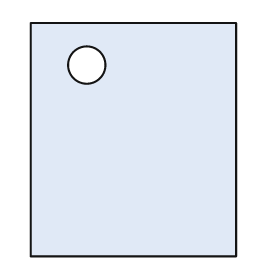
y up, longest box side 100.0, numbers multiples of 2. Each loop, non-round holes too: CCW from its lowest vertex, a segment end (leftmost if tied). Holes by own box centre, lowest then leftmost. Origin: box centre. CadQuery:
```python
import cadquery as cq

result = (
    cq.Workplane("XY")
    .moveTo(-44.0, -50.0)
    .lineTo(44.0, -50.0)
    .lineTo(44.0, 50.0)
    .lineTo(-44.0, 50.0)
    .close()
    .moveTo(-20.0, 32.0)
    .circle(8.0)
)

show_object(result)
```